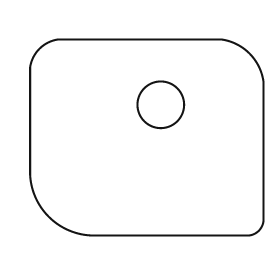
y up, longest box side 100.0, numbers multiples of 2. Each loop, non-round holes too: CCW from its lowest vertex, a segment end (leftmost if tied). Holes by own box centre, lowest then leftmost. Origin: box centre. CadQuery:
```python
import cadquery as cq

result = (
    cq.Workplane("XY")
    .moveTo(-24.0, -42.0)
    .lineTo(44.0, -42.0)
    .threePointArc((48.0, -40.0), (50.0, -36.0))
    .lineTo(50.0, 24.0)
    .threePointArc((44.0, 36.0), (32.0, 42.0))
    .lineTo(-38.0, 42.0)
    .threePointArc((-46.0, 38.0), (-50.0, 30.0))
    .lineTo(-50.0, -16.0)
    .threePointArc((-42.0, -34.0), (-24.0, -42.0))
    .close()
    .moveTo(6.0, 14.0)
    .circle(10.0)
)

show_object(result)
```